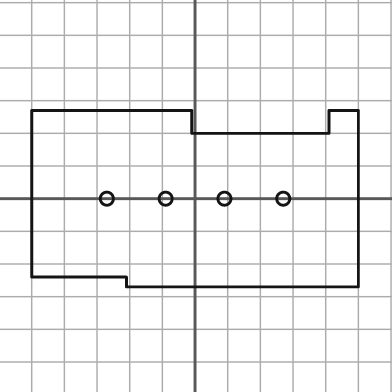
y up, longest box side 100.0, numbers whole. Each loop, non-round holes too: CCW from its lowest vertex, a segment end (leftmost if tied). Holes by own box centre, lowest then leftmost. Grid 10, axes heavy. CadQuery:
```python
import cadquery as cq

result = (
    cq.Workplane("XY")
    .moveTo(-21.0, -27.0)
    .lineTo(50.0, -27.0)
    .lineTo(50.0, 27.0)
    .lineTo(41.0, 27.0)
    .lineTo(41.0, 20.0)
    .lineTo(-1.0, 20.0)
    .lineTo(-1.0, 27.0)
    .lineTo(-50.0, 27.0)
    .lineTo(-50.0, -24.0)
    .lineTo(-21.0, -24.0)
    .close()
    .moveTo(-27.0, 0.0)
    .circle(2.0)
    .moveTo(-9.0, 0.0)
    .circle(2.0)
    .moveTo(9.0, 0.0)
    .circle(2.0)
    .moveTo(27.0, 0.0)
    .circle(2.0)
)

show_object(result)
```